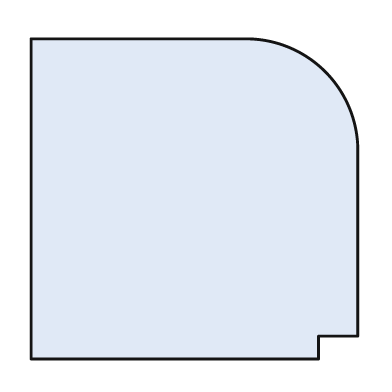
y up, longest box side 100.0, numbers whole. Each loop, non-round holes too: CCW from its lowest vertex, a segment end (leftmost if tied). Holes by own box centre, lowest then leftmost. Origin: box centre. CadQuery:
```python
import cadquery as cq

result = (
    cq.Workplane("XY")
    .moveTo(-50.0, -49.0)
    .lineTo(38.0, -49.0)
    .lineTo(38.0, -42.0)
    .lineTo(50.0, -42.0)
    .lineTo(50.0, 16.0)
    .threePointArc((40.0, 39.0), (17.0, 49.0))
    .lineTo(-50.0, 49.0)
    .close()
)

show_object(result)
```